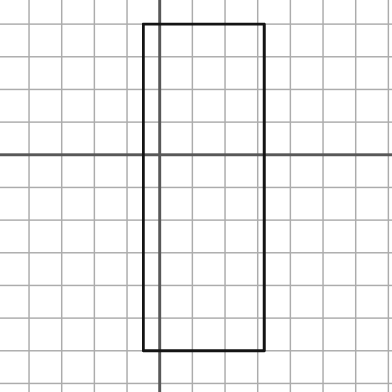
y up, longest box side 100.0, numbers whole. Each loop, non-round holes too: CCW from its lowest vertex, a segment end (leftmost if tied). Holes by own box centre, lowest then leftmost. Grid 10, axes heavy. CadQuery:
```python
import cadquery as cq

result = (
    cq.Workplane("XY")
    .moveTo(-5.0, -60.0)
    .lineTo(32.0, -60.0)
    .lineTo(32.0, 40.0)
    .lineTo(-5.0, 40.0)
    .close()
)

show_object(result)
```